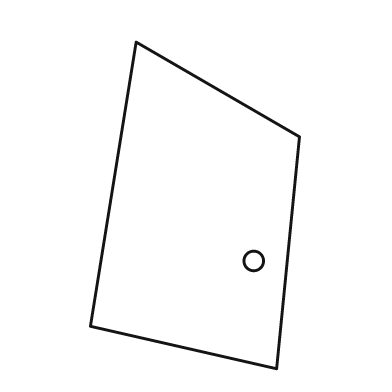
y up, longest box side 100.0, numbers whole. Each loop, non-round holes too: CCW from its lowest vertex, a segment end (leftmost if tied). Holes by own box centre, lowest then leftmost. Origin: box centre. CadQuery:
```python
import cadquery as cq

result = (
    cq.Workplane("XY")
    .moveTo(25.0, -50.0)
    .lineTo(32.0, 21.0)
    .lineTo(-18.0, 50.0)
    .lineTo(-32.0, -37.0)
    .close()
    .moveTo(18.0, -17.0)
    .circle(3.0)
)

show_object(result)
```